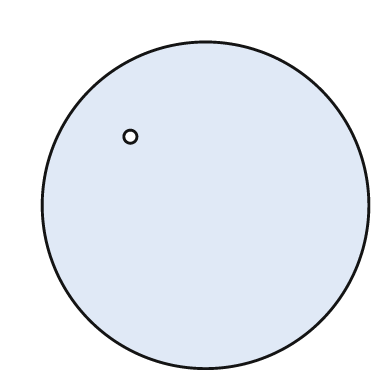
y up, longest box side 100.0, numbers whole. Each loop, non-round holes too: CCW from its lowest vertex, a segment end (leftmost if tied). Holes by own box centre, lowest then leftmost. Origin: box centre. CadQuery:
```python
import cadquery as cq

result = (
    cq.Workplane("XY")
    .moveTo(0.0, 0.0)
    .circle(50.0)
    .moveTo(-23.0, 21.0)
    .circle(2.0)
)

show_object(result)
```